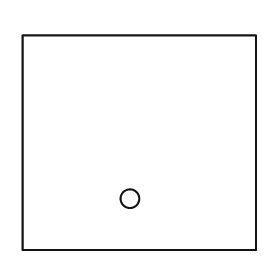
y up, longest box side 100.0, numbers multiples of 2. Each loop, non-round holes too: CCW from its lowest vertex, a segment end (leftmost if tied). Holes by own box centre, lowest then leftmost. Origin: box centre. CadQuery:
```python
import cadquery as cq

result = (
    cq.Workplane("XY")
    .moveTo(-50.0, -46.0)
    .lineTo(50.0, -46.0)
    .lineTo(50.0, 46.0)
    .lineTo(-50.0, 46.0)
    .close()
    .moveTo(-4.0, -24.0)
    .circle(4.0)
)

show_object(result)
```